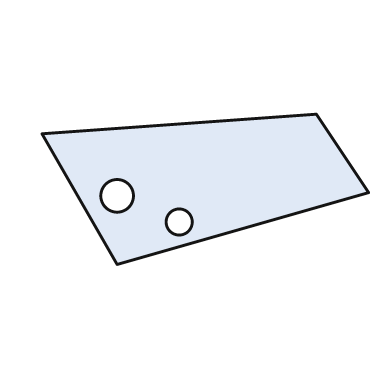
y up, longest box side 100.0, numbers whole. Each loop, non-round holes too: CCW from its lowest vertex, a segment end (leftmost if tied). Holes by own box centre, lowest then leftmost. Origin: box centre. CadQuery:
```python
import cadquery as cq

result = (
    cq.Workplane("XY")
    .moveTo(-27.0, -23.0)
    .lineTo(50.0, -1.0)
    .lineTo(34.0, 23.0)
    .lineTo(-50.0, 17.0)
    .close()
    .moveTo(-8.0, -10.0)
    .circle(4.0)
    .moveTo(-27.0, -2.0)
    .circle(5.0)
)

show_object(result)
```